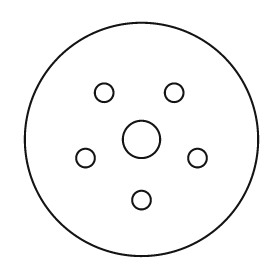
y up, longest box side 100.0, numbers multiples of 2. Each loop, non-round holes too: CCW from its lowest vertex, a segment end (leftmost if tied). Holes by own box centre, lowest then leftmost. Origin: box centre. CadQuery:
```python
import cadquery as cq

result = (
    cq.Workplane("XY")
    .moveTo(0.0, 0.0)
    .circle(50.0)
    .moveTo(0.0, -26.0)
    .circle(4.0)
    .moveTo(-24.0, -8.0)
    .circle(4.0)
    .moveTo(24.0, -8.0)
    .circle(4.0)
    .moveTo(0.0, 0.0)
    .circle(8.0)
    .moveTo(-16.0, 20.0)
    .circle(4.0)
    .moveTo(14.0, 20.0)
    .circle(4.0)
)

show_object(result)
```